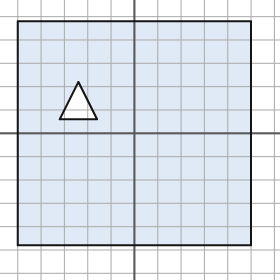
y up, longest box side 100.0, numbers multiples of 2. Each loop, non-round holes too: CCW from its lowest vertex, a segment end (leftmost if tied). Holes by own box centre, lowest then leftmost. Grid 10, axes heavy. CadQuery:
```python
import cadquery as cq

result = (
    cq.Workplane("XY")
    .moveTo(-50.0, -48.0)
    .lineTo(50.0, -48.0)
    .lineTo(50.0, 48.0)
    .lineTo(-50.0, 48.0)
    .close()
    .moveTo(-32.0, 6.0)
    .lineTo(-16.0, 6.0)
    .lineTo(-24.0, 22.0)
    .close()
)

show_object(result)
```